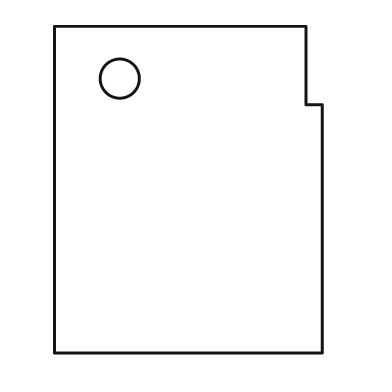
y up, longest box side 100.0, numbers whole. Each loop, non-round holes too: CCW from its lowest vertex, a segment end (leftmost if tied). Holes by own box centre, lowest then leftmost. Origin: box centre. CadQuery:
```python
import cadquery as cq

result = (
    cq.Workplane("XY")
    .moveTo(-41.0, -50.0)
    .lineTo(41.0, -50.0)
    .lineTo(41.0, 26.0)
    .lineTo(36.0, 26.0)
    .lineTo(36.0, 50.0)
    .lineTo(-41.0, 50.0)
    .close()
    .moveTo(-21.0, 34.0)
    .circle(6.0)
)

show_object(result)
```